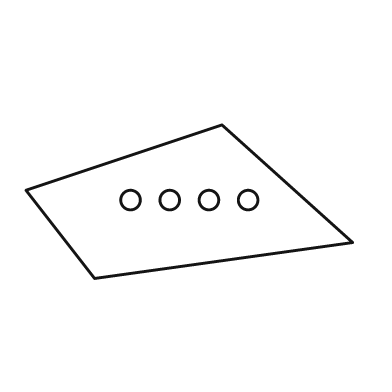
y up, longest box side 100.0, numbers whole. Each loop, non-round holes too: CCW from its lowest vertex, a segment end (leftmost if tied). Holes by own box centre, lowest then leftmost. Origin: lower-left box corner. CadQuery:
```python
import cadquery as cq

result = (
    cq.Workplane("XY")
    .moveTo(21.0, 0.0)
    .lineTo(100.0, 11.0)
    .lineTo(60.0, 47.0)
    .lineTo(0.0, 27.0)
    .close()
    .moveTo(32.0, 24.0)
    .circle(3.0)
    .moveTo(44.0, 24.0)
    .circle(3.0)
    .moveTo(56.0, 24.0)
    .circle(3.0)
    .moveTo(68.0, 24.0)
    .circle(3.0)
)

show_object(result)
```